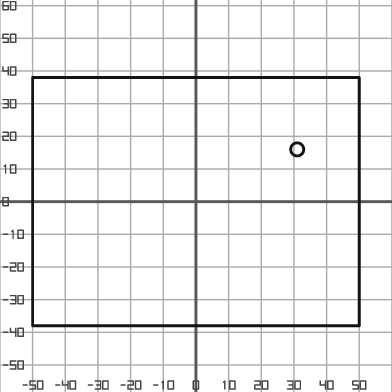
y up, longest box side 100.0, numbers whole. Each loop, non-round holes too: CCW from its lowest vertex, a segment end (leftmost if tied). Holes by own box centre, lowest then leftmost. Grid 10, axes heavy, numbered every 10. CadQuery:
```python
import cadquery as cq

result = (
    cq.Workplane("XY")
    .moveTo(-50.0, -38.0)
    .lineTo(50.0, -38.0)
    .lineTo(50.0, 38.0)
    .lineTo(-50.0, 38.0)
    .close()
    .moveTo(31.0, 16.0)
    .circle(2.0)
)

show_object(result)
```